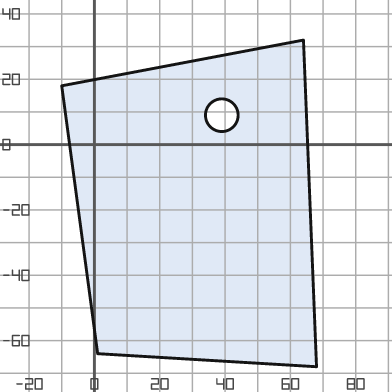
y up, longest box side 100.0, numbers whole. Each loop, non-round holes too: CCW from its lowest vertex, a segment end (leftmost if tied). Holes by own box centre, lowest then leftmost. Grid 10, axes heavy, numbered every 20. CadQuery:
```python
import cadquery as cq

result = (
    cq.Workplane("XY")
    .moveTo(68.0, -68.0)
    .lineTo(64.0, 32.0)
    .lineTo(-10.0, 18.0)
    .lineTo(1.0, -64.0)
    .close()
    .moveTo(39.0, 9.0)
    .circle(5.0)
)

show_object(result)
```